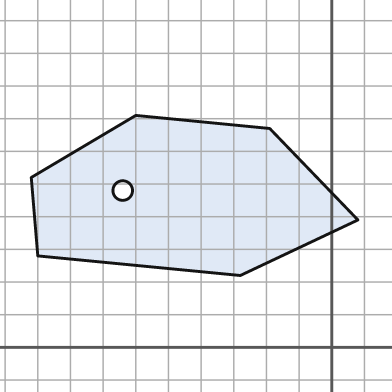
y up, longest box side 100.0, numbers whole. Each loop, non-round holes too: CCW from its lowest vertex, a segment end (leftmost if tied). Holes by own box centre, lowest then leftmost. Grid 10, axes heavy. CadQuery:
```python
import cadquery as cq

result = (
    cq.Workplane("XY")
    .moveTo(-28.0, 22.0)
    .lineTo(8.0, 39.0)
    .lineTo(-19.0, 67.0)
    .lineTo(-60.0, 71.0)
    .lineTo(-92.0, 52.0)
    .lineTo(-90.0, 28.0)
    .close()
    .moveTo(-64.0, 48.0)
    .circle(3.0)
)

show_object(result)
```